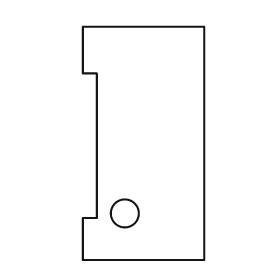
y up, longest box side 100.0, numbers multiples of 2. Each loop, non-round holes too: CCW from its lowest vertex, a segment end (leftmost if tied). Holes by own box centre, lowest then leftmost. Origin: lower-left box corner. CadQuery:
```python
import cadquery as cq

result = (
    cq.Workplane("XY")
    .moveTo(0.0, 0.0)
    .lineTo(52.0, 0.0)
    .lineTo(52.0, 100.0)
    .lineTo(0.0, 100.0)
    .lineTo(0.0, 80.0)
    .lineTo(6.0, 80.0)
    .lineTo(6.0, 18.0)
    .lineTo(0.0, 18.0)
    .close()
    .moveTo(18.0, 20.0)
    .circle(6.0)
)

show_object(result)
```